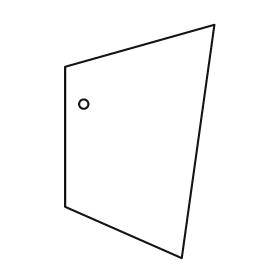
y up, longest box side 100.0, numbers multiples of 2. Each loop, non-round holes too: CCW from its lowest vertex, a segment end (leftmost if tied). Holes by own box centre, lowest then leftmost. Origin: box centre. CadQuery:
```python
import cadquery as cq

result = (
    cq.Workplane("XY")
    .moveTo(18.0, -50.0)
    .lineTo(32.0, 50.0)
    .lineTo(-32.0, 32.0)
    .lineTo(-32.0, -28.0)
    .close()
    .moveTo(-24.0, 16.0)
    .circle(2.0)
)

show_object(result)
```